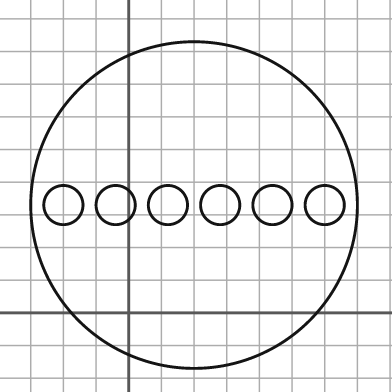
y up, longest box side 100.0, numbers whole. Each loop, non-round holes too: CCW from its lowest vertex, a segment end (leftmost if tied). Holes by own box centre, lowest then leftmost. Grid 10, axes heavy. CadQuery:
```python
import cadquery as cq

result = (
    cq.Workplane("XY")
    .moveTo(20.0, 33.0)
    .circle(50.0)
    .moveTo(-20.0, 33.0)
    .circle(6.0)
    .moveTo(-4.0, 33.0)
    .circle(6.0)
    .moveTo(12.0, 33.0)
    .circle(6.0)
    .moveTo(28.0, 33.0)
    .circle(6.0)
    .moveTo(44.0, 33.0)
    .circle(6.0)
    .moveTo(60.0, 33.0)
    .circle(6.0)
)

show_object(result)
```